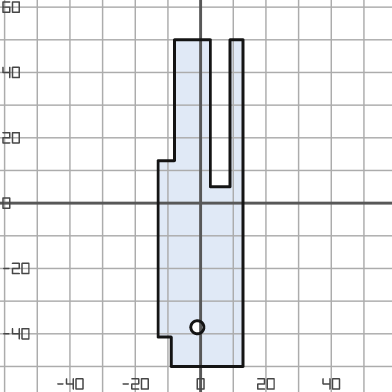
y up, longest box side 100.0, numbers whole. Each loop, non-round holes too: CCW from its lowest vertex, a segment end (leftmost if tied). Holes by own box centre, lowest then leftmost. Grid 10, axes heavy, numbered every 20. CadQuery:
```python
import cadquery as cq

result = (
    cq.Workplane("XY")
    .moveTo(-9.0, -50.0)
    .lineTo(13.0, -50.0)
    .lineTo(13.0, 50.0)
    .lineTo(9.0, 50.0)
    .lineTo(9.0, 5.0)
    .lineTo(3.0, 5.0)
    .lineTo(3.0, 50.0)
    .lineTo(-8.0, 50.0)
    .lineTo(-8.0, 13.0)
    .lineTo(-13.0, 13.0)
    .lineTo(-13.0, -41.0)
    .lineTo(-9.0, -41.0)
    .close()
    .moveTo(-1.0, -38.0)
    .circle(2.0)
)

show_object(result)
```